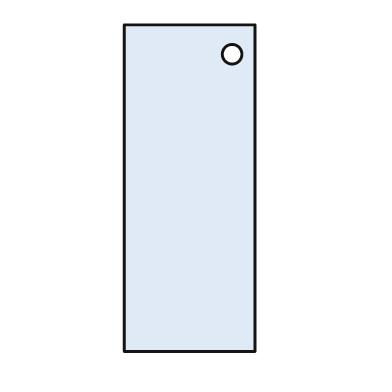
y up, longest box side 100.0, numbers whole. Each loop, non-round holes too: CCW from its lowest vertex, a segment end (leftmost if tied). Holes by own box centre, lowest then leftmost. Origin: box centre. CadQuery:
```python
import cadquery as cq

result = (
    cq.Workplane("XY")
    .moveTo(-20.0, -50.0)
    .lineTo(20.0, -50.0)
    .lineTo(20.0, 50.0)
    .lineTo(-20.0, 50.0)
    .close()
    .moveTo(13.0, 41.0)
    .circle(3.0)
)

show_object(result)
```